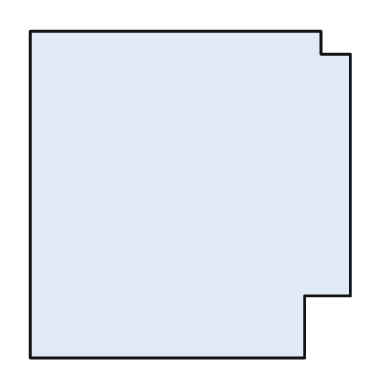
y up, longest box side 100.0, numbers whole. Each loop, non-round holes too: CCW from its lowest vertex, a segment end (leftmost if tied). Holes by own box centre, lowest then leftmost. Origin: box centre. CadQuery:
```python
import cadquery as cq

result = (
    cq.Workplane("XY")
    .moveTo(-49.0, -50.0)
    .lineTo(35.0, -50.0)
    .lineTo(35.0, -31.0)
    .lineTo(49.0, -31.0)
    .lineTo(49.0, 43.0)
    .lineTo(40.0, 43.0)
    .lineTo(40.0, 50.0)
    .lineTo(-49.0, 50.0)
    .close()
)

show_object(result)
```